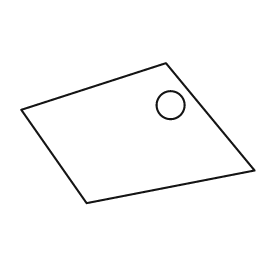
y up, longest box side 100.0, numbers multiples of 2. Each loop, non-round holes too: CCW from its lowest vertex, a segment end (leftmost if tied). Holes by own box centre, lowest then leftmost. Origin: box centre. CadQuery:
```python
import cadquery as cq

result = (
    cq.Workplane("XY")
    .moveTo(-22.0, -30.0)
    .lineTo(50.0, -16.0)
    .lineTo(12.0, 30.0)
    .lineTo(-50.0, 10.0)
    .close()
    .moveTo(14.0, 12.0)
    .circle(6.0)
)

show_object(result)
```